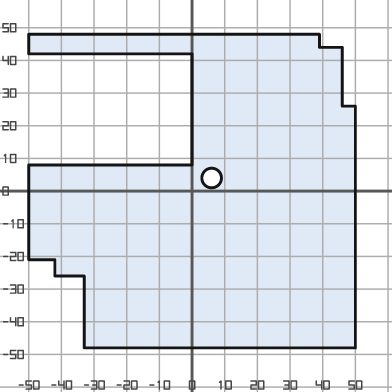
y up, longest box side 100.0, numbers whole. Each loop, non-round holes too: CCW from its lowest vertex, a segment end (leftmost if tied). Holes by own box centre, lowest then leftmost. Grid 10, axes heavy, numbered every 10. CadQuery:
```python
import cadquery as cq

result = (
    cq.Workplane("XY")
    .moveTo(-33.0, -48.0)
    .lineTo(50.0, -48.0)
    .lineTo(50.0, 26.0)
    .lineTo(46.0, 26.0)
    .lineTo(46.0, 44.0)
    .lineTo(39.0, 44.0)
    .lineTo(39.0, 48.0)
    .lineTo(-50.0, 48.0)
    .lineTo(-50.0, 42.0)
    .lineTo(0.0, 42.0)
    .lineTo(0.0, 8.0)
    .lineTo(-50.0, 8.0)
    .lineTo(-50.0, -21.0)
    .lineTo(-42.0, -21.0)
    .lineTo(-42.0, -26.0)
    .lineTo(-33.0, -26.0)
    .close()
    .moveTo(6.0, 4.0)
    .circle(3.0)
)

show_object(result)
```